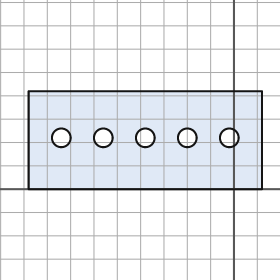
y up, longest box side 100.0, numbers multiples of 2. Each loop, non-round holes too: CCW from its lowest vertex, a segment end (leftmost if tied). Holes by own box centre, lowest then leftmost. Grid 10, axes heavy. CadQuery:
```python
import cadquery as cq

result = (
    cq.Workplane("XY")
    .moveTo(-88.0, 0.0)
    .lineTo(12.0, 0.0)
    .lineTo(12.0, 42.0)
    .lineTo(-88.0, 42.0)
    .close()
    .moveTo(-74.0, 22.0)
    .circle(4.0)
    .moveTo(-56.0, 22.0)
    .circle(4.0)
    .moveTo(-38.0, 22.0)
    .circle(4.0)
    .moveTo(-20.0, 22.0)
    .circle(4.0)
    .moveTo(-2.0, 22.0)
    .circle(4.0)
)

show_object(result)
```